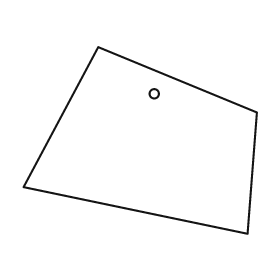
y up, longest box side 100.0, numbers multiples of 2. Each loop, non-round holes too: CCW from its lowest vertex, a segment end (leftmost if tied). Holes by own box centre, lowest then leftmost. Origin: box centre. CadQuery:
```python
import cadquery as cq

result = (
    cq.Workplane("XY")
    .moveTo(46.0, -40.0)
    .lineTo(50.0, 12.0)
    .lineTo(-18.0, 40.0)
    .lineTo(-50.0, -20.0)
    .close()
    .moveTo(6.0, 20.0)
    .circle(2.0)
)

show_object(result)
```